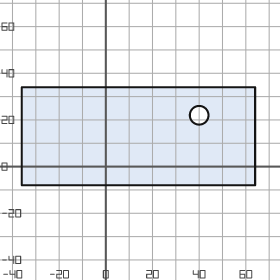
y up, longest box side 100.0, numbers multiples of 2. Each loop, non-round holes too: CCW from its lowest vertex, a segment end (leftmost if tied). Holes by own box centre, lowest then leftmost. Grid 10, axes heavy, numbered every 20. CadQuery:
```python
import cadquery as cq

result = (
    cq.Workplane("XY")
    .moveTo(-36.0, -8.0)
    .lineTo(64.0, -8.0)
    .lineTo(64.0, 34.0)
    .lineTo(-36.0, 34.0)
    .close()
    .moveTo(40.0, 22.0)
    .circle(4.0)
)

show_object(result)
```